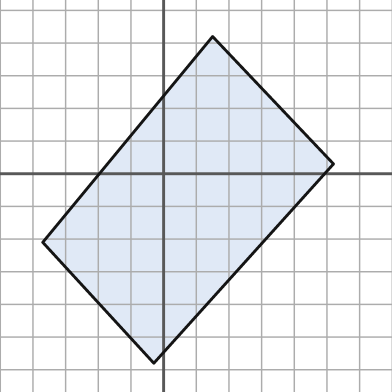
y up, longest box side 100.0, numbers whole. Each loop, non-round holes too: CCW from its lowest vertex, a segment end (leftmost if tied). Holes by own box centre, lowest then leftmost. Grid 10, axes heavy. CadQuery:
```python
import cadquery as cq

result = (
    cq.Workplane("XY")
    .moveTo(-3.0, -58.0)
    .lineTo(52.0, 3.0)
    .lineTo(15.0, 42.0)
    .lineTo(-37.0, -21.0)
    .close()
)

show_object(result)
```